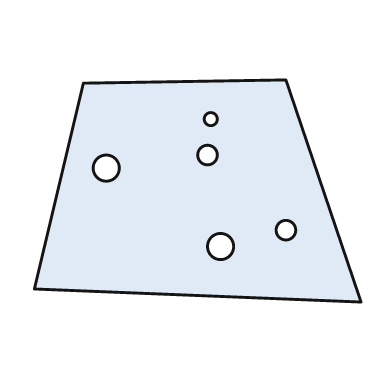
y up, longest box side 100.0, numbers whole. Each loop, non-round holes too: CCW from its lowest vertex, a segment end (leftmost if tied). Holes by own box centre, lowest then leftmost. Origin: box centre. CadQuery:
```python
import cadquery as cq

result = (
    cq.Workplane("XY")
    .moveTo(50.0, -34.0)
    .lineTo(27.0, 34.0)
    .lineTo(-35.0, 33.0)
    .lineTo(-50.0, -30.0)
    .close()
    .moveTo(7.0, -17.0)
    .circle(4.0)
    .moveTo(27.0, -12.0)
    .circle(3.0)
    .moveTo(-28.0, 7.0)
    .circle(4.0)
    .moveTo(3.0, 11.0)
    .circle(3.0)
    .moveTo(4.0, 22.0)
    .circle(2.0)
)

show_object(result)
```